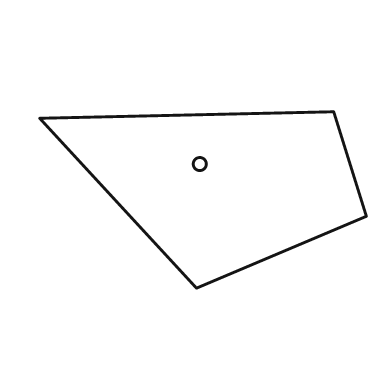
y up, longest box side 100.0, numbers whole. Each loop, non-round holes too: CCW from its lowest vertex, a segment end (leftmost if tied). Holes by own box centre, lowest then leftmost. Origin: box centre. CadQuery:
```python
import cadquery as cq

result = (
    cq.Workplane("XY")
    .moveTo(-2.0, -27.0)
    .lineTo(50.0, -5.0)
    .lineTo(40.0, 27.0)
    .lineTo(-50.0, 25.0)
    .close()
    .moveTo(-1.0, 11.0)
    .circle(2.0)
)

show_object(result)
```